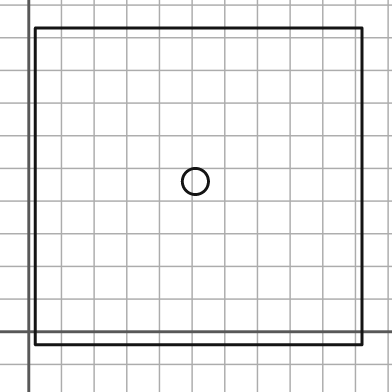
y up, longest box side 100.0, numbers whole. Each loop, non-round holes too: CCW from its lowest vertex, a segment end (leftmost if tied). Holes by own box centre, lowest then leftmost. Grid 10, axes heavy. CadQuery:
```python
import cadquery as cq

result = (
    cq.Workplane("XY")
    .moveTo(2.0, -4.0)
    .lineTo(102.0, -4.0)
    .lineTo(102.0, 93.0)
    .lineTo(2.0, 93.0)
    .close()
    .moveTo(51.0, 46.0)
    .circle(4.0)
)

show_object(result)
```